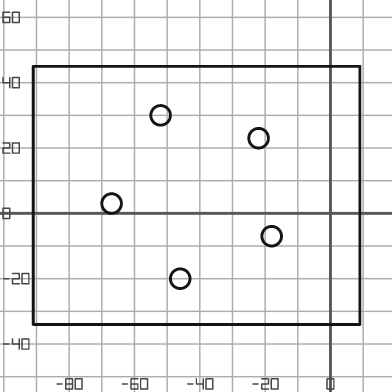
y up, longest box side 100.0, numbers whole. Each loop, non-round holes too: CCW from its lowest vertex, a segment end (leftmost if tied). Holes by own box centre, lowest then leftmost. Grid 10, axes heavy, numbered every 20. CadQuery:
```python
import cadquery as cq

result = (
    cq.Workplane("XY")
    .moveTo(-91.0, -34.0)
    .lineTo(9.0, -34.0)
    .lineTo(9.0, 45.0)
    .lineTo(-91.0, 45.0)
    .close()
    .moveTo(-46.0, -20.0)
    .circle(3.0)
    .moveTo(-18.0, -7.0)
    .circle(3.0)
    .moveTo(-67.0, 3.0)
    .circle(3.0)
    .moveTo(-22.0, 23.0)
    .circle(3.0)
    .moveTo(-52.0, 30.0)
    .circle(3.0)
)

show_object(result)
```